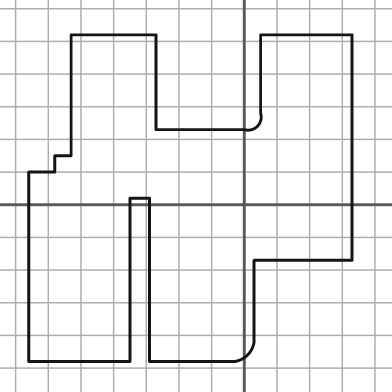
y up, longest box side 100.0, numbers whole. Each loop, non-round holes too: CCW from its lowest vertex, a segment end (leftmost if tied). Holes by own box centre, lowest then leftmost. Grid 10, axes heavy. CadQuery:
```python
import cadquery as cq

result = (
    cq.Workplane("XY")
    .moveTo(-66.0, -48.0)
    .lineTo(-35.0, -48.0)
    .lineTo(-35.0, 2.0)
    .lineTo(-29.0, 2.0)
    .lineTo(-29.0, -48.0)
    .lineTo(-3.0, -48.0)
    .threePointArc((1.0, -46.0), (3.0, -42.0))
    .lineTo(3.0, -17.0)
    .lineTo(33.0, -17.0)
    .lineTo(33.0, 52.0)
    .lineTo(5.0, 52.0)
    .lineTo(5.0, 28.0)
    .threePointArc((4.0, 24.0), (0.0, 23.0))
    .lineTo(-27.0, 23.0)
    .lineTo(-27.0, 52.0)
    .lineTo(-53.0, 52.0)
    .lineTo(-53.0, 15.0)
    .lineTo(-58.0, 15.0)
    .lineTo(-58.0, 10.0)
    .lineTo(-66.0, 10.0)
    .close()
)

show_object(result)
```